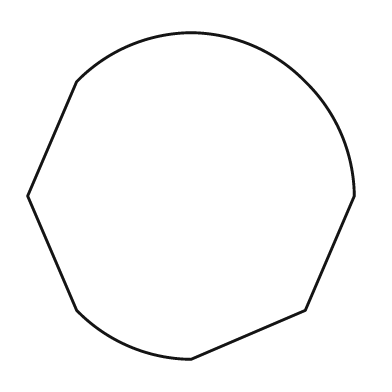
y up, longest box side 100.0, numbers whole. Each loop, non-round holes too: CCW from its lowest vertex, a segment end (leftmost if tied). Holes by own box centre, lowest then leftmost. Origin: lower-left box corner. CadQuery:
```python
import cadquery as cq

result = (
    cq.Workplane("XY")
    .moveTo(50.0, 0.0)
    .lineTo(85.0, 15.0)
    .lineTo(100.0, 50.0)
    .threePointArc((96.0, 69.0), (85.0, 85.0))
    .threePointArc((69.0, 96.0), (50.0, 100.0))
    .threePointArc((31.0, 96.0), (15.0, 85.0))
    .lineTo(0.0, 50.0)
    .lineTo(15.0, 15.0)
    .threePointArc((31.0, 4.0), (50.0, 0.0))
    .close()
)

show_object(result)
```